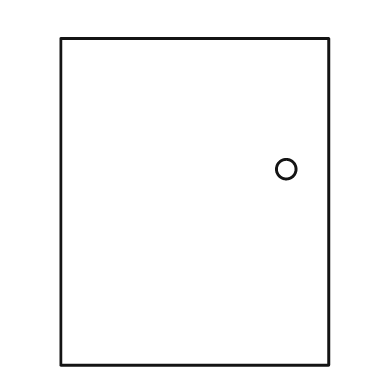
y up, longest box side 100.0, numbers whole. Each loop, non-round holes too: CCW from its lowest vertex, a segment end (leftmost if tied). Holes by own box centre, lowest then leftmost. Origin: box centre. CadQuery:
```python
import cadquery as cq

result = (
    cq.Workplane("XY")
    .moveTo(-41.0, -50.0)
    .lineTo(41.0, -50.0)
    .lineTo(41.0, 50.0)
    .lineTo(-41.0, 50.0)
    .close()
    .moveTo(28.0, 10.0)
    .circle(3.0)
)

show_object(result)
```